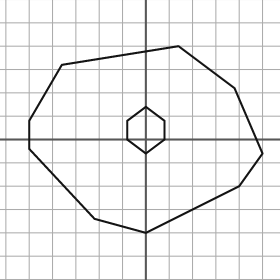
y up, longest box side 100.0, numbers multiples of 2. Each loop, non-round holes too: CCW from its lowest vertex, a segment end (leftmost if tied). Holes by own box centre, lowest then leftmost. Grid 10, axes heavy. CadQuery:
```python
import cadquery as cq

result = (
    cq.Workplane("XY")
    .moveTo(0.0, -40.0)
    .lineTo(40.0, -20.0)
    .lineTo(50.0, -6.0)
    .lineTo(38.0, 22.0)
    .lineTo(14.0, 40.0)
    .lineTo(-36.0, 32.0)
    .lineTo(-50.0, 8.0)
    .lineTo(-50.0, -4.0)
    .lineTo(-22.0, -34.0)
    .close()
    .moveTo(0.0, -6.0)
    .lineTo(8.0, 0.0)
    .lineTo(8.0, 8.0)
    .lineTo(0.0, 14.0)
    .lineTo(-8.0, 8.0)
    .lineTo(-8.0, 0.0)
    .close()
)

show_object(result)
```